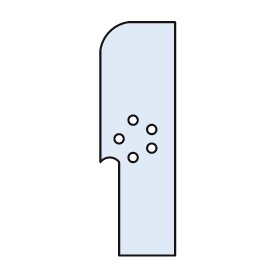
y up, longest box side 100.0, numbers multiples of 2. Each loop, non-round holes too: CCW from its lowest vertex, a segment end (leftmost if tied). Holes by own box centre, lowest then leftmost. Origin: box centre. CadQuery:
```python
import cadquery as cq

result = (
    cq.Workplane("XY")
    .moveTo(-8.0, -50.0)
    .lineTo(16.0, -50.0)
    .lineTo(16.0, 50.0)
    .lineTo(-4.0, 50.0)
    .threePointArc((-12.0, 46.0), (-16.0, 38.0))
    .lineTo(-16.0, -10.0)
    .threePointArc((-12.0, -8.0), (-8.0, -10.0))
    .close()
    .moveTo(-2.0, -8.0)
    .circle(2.0)
    .moveTo(6.0, -4.0)
    .circle(2.0)
    .moveTo(-8.0, 0.0)
    .circle(2.0)
    .moveTo(6.0, 4.0)
    .circle(2.0)
    .moveTo(-2.0, 8.0)
    .circle(2.0)
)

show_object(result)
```